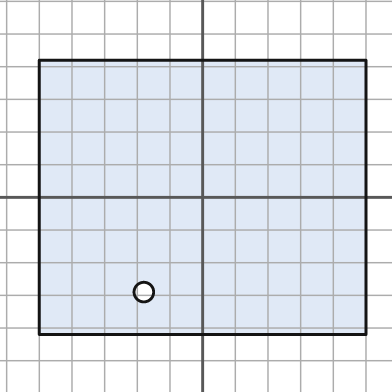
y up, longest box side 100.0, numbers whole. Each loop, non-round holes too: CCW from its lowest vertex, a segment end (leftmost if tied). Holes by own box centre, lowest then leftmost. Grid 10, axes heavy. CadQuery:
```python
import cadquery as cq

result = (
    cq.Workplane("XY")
    .moveTo(-50.0, -42.0)
    .lineTo(50.0, -42.0)
    .lineTo(50.0, 42.0)
    .lineTo(-50.0, 42.0)
    .close()
    .moveTo(-18.0, -29.0)
    .circle(3.0)
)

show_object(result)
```